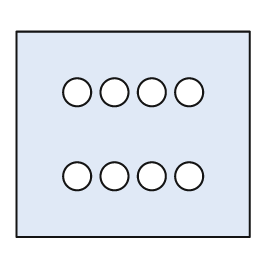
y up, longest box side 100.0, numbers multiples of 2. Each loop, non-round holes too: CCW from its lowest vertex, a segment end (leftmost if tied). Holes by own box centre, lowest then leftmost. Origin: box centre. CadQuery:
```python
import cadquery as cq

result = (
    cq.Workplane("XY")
    .moveTo(-50.0, -44.0)
    .lineTo(50.0, -44.0)
    .lineTo(50.0, 44.0)
    .lineTo(-50.0, 44.0)
    .close()
    .moveTo(-24.0, -18.0)
    .circle(6.0)
    .moveTo(-8.0, -18.0)
    .circle(6.0)
    .moveTo(8.0, -18.0)
    .circle(6.0)
    .moveTo(24.0, -18.0)
    .circle(6.0)
    .moveTo(-24.0, 18.0)
    .circle(6.0)
    .moveTo(-8.0, 18.0)
    .circle(6.0)
    .moveTo(8.0, 18.0)
    .circle(6.0)
    .moveTo(24.0, 18.0)
    .circle(6.0)
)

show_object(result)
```